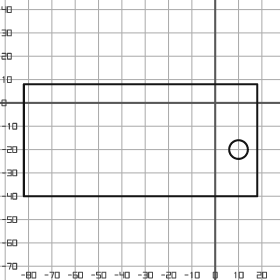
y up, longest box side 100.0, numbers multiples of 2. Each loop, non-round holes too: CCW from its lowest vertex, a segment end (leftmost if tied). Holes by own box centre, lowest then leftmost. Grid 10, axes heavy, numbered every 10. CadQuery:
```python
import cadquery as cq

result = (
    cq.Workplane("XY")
    .moveTo(-82.0, -40.0)
    .lineTo(18.0, -40.0)
    .lineTo(18.0, 8.0)
    .lineTo(-82.0, 8.0)
    .close()
    .moveTo(10.0, -20.0)
    .circle(4.0)
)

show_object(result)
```